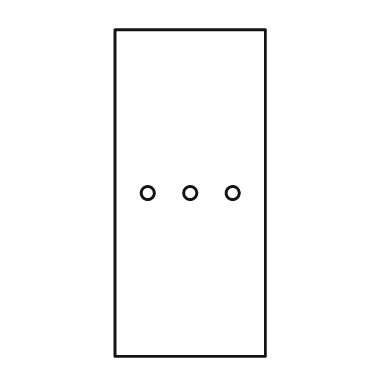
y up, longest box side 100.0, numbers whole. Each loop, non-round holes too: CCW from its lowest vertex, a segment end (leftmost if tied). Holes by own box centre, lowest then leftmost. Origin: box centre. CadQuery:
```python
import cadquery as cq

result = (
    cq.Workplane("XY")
    .moveTo(-23.0, -50.0)
    .lineTo(23.0, -50.0)
    .lineTo(23.0, 50.0)
    .lineTo(-23.0, 50.0)
    .close()
    .moveTo(-13.0, 0.0)
    .circle(2.0)
    .moveTo(0.0, 0.0)
    .circle(2.0)
    .moveTo(13.0, 0.0)
    .circle(2.0)
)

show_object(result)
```